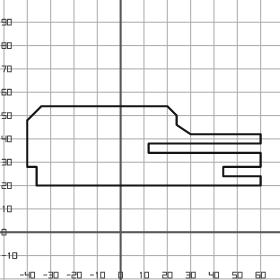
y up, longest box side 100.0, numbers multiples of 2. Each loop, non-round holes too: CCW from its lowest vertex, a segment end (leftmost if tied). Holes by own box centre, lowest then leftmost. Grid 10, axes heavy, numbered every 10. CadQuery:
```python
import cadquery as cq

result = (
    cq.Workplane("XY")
    .moveTo(-36.0, 20.0)
    .lineTo(60.0, 20.0)
    .lineTo(60.0, 24.0)
    .lineTo(44.0, 24.0)
    .lineTo(44.0, 28.0)
    .lineTo(60.0, 28.0)
    .lineTo(60.0, 34.0)
    .lineTo(12.0, 34.0)
    .lineTo(12.0, 38.0)
    .lineTo(60.0, 38.0)
    .lineTo(60.0, 42.0)
    .lineTo(30.0, 42.0)
    .lineTo(24.0, 46.0)
    .lineTo(24.0, 50.0)
    .lineTo(20.0, 54.0)
    .lineTo(-34.0, 54.0)
    .lineTo(-40.0, 48.0)
    .lineTo(-40.0, 28.0)
    .lineTo(-36.0, 28.0)
    .close()
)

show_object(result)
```